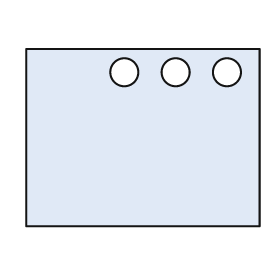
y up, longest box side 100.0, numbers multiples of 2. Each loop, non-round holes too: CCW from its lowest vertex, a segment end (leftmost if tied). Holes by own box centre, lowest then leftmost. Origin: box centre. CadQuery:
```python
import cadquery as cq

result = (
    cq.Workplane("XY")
    .moveTo(-50.0, -38.0)
    .lineTo(50.0, -38.0)
    .lineTo(50.0, 38.0)
    .lineTo(-50.0, 38.0)
    .close()
    .moveTo(-8.0, 28.0)
    .circle(6.0)
    .moveTo(14.0, 28.0)
    .circle(6.0)
    .moveTo(36.0, 28.0)
    .circle(6.0)
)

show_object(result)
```